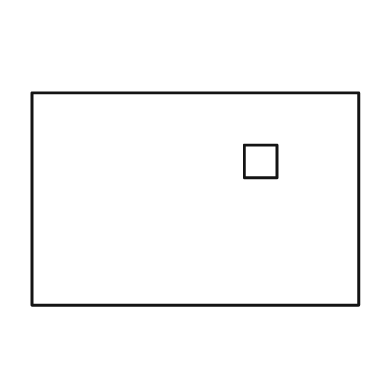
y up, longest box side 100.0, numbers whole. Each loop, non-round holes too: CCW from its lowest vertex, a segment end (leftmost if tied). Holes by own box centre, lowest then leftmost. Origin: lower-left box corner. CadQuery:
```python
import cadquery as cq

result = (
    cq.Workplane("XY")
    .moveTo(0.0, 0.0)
    .lineTo(100.0, 0.0)
    .lineTo(100.0, 65.0)
    .lineTo(0.0, 65.0)
    .close()
    .moveTo(65.0, 39.0)
    .lineTo(75.0, 39.0)
    .lineTo(75.0, 49.0)
    .lineTo(65.0, 49.0)
    .close()
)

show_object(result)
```